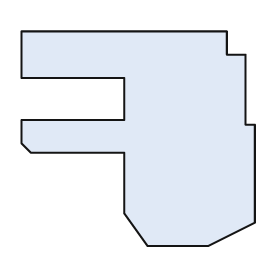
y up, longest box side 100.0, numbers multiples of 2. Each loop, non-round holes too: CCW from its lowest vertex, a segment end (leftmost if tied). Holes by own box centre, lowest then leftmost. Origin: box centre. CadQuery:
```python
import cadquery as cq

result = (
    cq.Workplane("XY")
    .moveTo(4.0, -46.0)
    .lineTo(30.0, -46.0)
    .lineTo(50.0, -36.0)
    .lineTo(50.0, 6.0)
    .lineTo(46.0, 6.0)
    .lineTo(46.0, 36.0)
    .lineTo(38.0, 36.0)
    .lineTo(38.0, 46.0)
    .lineTo(-50.0, 46.0)
    .lineTo(-50.0, 26.0)
    .lineTo(-6.0, 26.0)
    .lineTo(-6.0, 8.0)
    .lineTo(-50.0, 8.0)
    .lineTo(-50.0, -2.0)
    .lineTo(-46.0, -6.0)
    .lineTo(-6.0, -6.0)
    .lineTo(-6.0, -32.0)
    .close()
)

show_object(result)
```